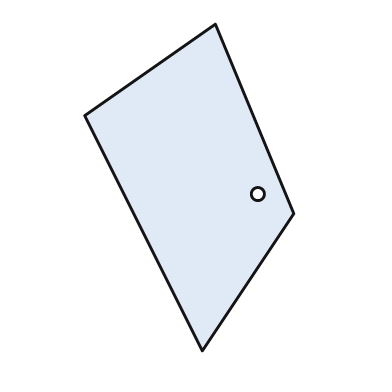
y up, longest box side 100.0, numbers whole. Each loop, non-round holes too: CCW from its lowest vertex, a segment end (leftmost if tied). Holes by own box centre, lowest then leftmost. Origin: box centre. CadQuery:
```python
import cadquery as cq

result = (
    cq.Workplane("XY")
    .moveTo(4.0, -50.0)
    .lineTo(32.0, -8.0)
    .lineTo(8.0, 50.0)
    .lineTo(-32.0, 22.0)
    .close()
    .moveTo(21.0, -2.0)
    .circle(2.0)
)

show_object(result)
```